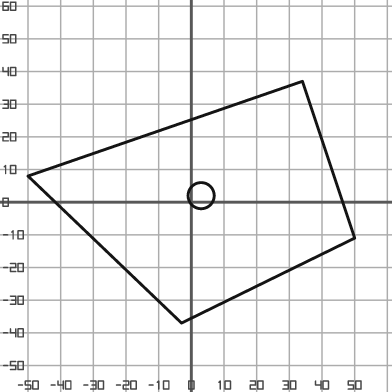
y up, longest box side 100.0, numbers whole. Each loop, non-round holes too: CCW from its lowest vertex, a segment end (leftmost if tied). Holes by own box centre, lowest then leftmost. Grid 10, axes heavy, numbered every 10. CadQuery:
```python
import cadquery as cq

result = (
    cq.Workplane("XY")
    .moveTo(-3.0, -37.0)
    .lineTo(50.0, -11.0)
    .lineTo(34.0, 37.0)
    .lineTo(-50.0, 8.0)
    .close()
    .moveTo(3.0, 2.0)
    .circle(4.0)
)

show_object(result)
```